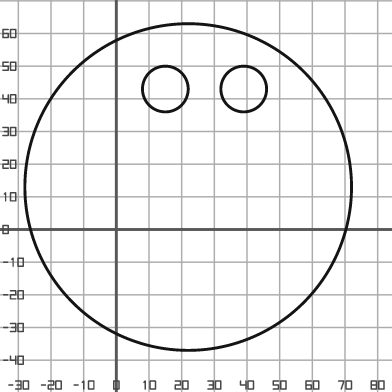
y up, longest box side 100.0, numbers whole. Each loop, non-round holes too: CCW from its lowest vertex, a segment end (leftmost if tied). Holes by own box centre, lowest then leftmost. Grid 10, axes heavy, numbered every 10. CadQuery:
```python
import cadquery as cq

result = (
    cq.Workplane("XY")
    .moveTo(22.0, 13.0)
    .circle(50.0)
    .moveTo(15.0, 43.0)
    .circle(7.0)
    .moveTo(39.0, 43.0)
    .circle(7.0)
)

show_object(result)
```